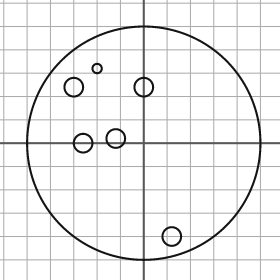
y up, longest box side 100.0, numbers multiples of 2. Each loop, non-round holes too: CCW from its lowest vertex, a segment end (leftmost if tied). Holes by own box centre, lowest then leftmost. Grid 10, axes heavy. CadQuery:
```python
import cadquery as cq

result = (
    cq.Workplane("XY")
    .moveTo(0.0, 0.0)
    .circle(50.0)
    .moveTo(12.0, -40.0)
    .circle(4.0)
    .moveTo(-26.0, 0.0)
    .circle(4.0)
    .moveTo(-12.0, 2.0)
    .circle(4.0)
    .moveTo(-30.0, 24.0)
    .circle(4.0)
    .moveTo(0.0, 24.0)
    .circle(4.0)
    .moveTo(-20.0, 32.0)
    .circle(2.0)
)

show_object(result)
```